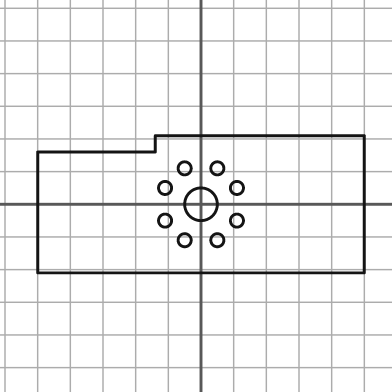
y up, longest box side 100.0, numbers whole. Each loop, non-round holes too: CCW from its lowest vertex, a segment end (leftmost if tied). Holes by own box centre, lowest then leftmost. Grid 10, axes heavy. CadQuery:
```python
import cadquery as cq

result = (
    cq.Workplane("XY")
    .moveTo(-50.0, -21.0)
    .lineTo(50.0, -21.0)
    .lineTo(50.0, 21.0)
    .lineTo(-14.0, 21.0)
    .lineTo(-14.0, 16.0)
    .lineTo(-50.0, 16.0)
    .close()
    .moveTo(-5.0, -11.0)
    .circle(2.0)
    .moveTo(5.0, -11.0)
    .circle(2.0)
    .moveTo(-11.0, -5.0)
    .circle(2.0)
    .moveTo(11.0, -5.0)
    .circle(2.0)
    .moveTo(0.0, 0.0)
    .circle(5.0)
    .moveTo(-11.0, 5.0)
    .circle(2.0)
    .moveTo(11.0, 5.0)
    .circle(2.0)
    .moveTo(-5.0, 11.0)
    .circle(2.0)
    .moveTo(5.0, 11.0)
    .circle(2.0)
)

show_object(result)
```